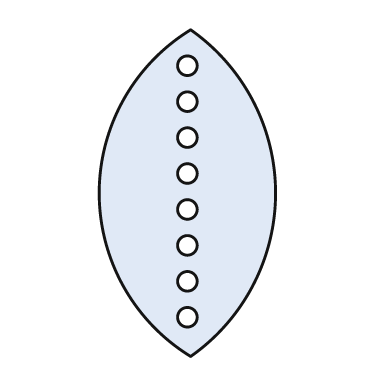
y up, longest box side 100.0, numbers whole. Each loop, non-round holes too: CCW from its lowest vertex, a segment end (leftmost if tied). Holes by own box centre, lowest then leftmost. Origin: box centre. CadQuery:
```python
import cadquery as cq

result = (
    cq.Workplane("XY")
    .moveTo(1.0, -50.0)
    .threePointArc((27.0, 0.0), (1.0, 50.0))
    .threePointArc((-27.0, 0.0), (1.0, -50.0))
    .close()
    .moveTo(0.0, -38.0)
    .circle(3.0)
    .moveTo(0.0, -27.0)
    .circle(3.0)
    .moveTo(0.0, -16.0)
    .circle(3.0)
    .moveTo(0.0, -5.0)
    .circle(3.0)
    .moveTo(0.0, 6.0)
    .circle(3.0)
    .moveTo(0.0, 17.0)
    .circle(3.0)
    .moveTo(0.0, 28.0)
    .circle(3.0)
    .moveTo(0.0, 39.0)
    .circle(3.0)
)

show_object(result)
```